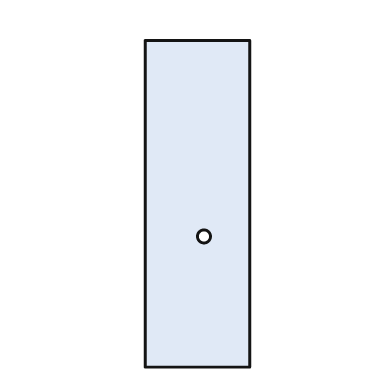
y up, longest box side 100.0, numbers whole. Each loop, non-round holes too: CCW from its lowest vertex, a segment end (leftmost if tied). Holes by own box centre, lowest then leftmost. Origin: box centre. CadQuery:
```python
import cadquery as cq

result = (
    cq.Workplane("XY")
    .moveTo(-16.0, -50.0)
    .lineTo(16.0, -50.0)
    .lineTo(16.0, 50.0)
    .lineTo(-16.0, 50.0)
    .close()
    .moveTo(2.0, -10.0)
    .circle(2.0)
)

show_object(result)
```